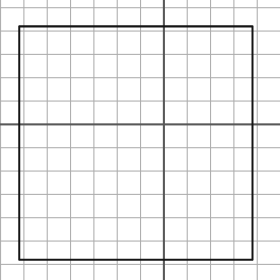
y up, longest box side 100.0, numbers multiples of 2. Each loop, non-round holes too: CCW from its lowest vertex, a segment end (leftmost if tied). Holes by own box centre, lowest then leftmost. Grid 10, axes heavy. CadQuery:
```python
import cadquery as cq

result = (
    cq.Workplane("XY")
    .moveTo(-62.0, -58.0)
    .lineTo(38.0, -58.0)
    .lineTo(38.0, 42.0)
    .lineTo(-62.0, 42.0)
    .close()
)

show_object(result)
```